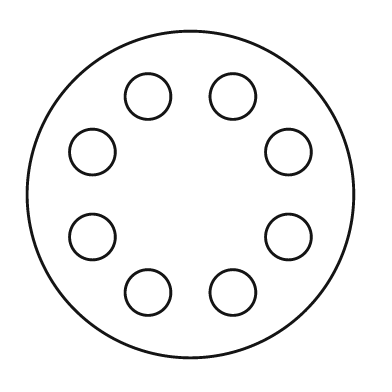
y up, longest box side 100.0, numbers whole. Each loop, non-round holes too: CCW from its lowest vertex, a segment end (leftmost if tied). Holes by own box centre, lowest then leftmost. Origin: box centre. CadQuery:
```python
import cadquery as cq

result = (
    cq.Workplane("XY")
    .moveTo(0.0, 0.0)
    .circle(50.0)
    .moveTo(-13.0, -30.0)
    .circle(7.0)
    .moveTo(13.0, -30.0)
    .circle(7.0)
    .moveTo(-30.0, -13.0)
    .circle(7.0)
    .moveTo(30.0, -13.0)
    .circle(7.0)
    .moveTo(-30.0, 13.0)
    .circle(7.0)
    .moveTo(30.0, 13.0)
    .circle(7.0)
    .moveTo(-13.0, 30.0)
    .circle(7.0)
    .moveTo(13.0, 30.0)
    .circle(7.0)
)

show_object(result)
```